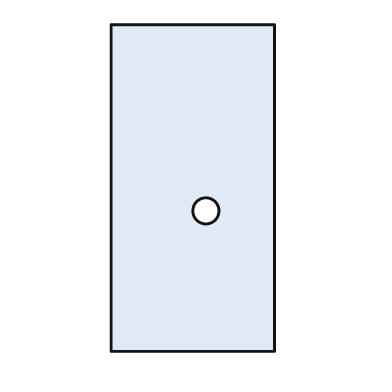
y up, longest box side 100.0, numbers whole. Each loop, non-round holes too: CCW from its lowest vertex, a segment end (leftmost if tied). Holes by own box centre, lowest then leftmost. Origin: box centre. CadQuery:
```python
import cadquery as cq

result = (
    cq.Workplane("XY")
    .moveTo(-25.0, -50.0)
    .lineTo(25.0, -50.0)
    .lineTo(25.0, 50.0)
    .lineTo(-25.0, 50.0)
    .close()
    .moveTo(4.0, -7.0)
    .circle(4.0)
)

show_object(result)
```